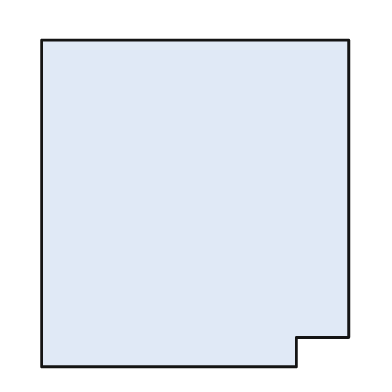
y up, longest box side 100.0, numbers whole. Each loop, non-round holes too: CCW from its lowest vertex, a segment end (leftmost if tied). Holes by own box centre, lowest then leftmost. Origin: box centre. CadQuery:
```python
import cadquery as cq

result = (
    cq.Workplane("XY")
    .moveTo(-47.0, -50.0)
    .lineTo(31.0, -50.0)
    .lineTo(31.0, -41.0)
    .lineTo(47.0, -41.0)
    .lineTo(47.0, 50.0)
    .lineTo(-47.0, 50.0)
    .close()
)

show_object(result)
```